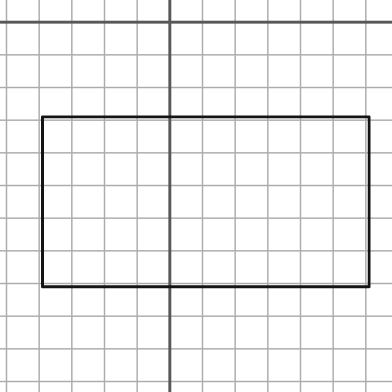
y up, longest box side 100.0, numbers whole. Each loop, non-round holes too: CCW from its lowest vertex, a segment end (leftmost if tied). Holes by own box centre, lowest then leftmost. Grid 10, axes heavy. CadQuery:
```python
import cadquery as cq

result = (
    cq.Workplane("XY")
    .moveTo(-39.0, -81.0)
    .lineTo(61.0, -81.0)
    .lineTo(61.0, -29.0)
    .lineTo(-39.0, -29.0)
    .close()
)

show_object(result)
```